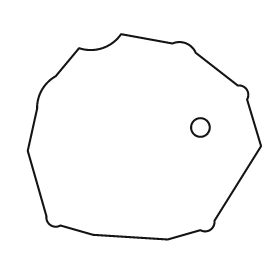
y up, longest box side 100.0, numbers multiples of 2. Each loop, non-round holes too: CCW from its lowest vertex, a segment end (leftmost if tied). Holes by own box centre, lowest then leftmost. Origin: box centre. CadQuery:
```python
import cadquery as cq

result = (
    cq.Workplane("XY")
    .moveTo(10.0, -44.0)
    .lineTo(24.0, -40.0)
    .threePointArc((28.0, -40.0), (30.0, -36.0))
    .lineTo(50.0, -4.0)
    .lineTo(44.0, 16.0)
    .threePointArc((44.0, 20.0), (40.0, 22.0))
    .lineTo(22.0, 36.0)
    .threePointArc((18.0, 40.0), (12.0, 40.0))
    .lineTo(-10.0, 44.0)
    .threePointArc((-18.0, 38.0), (-28.0, 38.0))
    .lineTo(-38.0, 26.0)
    .threePointArc((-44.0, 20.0), (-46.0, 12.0))
    .lineTo(-50.0, -6.0)
    .lineTo(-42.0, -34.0)
    .threePointArc((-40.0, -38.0), (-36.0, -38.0))
    .lineTo(-22.0, -42.0)
    .close()
    .moveTo(24.0, 4.0)
    .circle(4.0)
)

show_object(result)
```